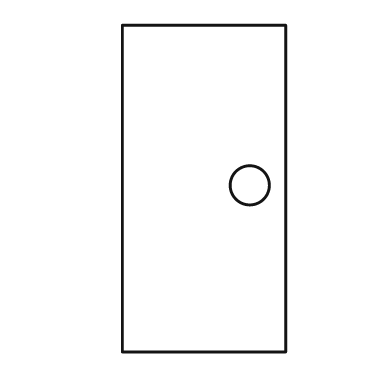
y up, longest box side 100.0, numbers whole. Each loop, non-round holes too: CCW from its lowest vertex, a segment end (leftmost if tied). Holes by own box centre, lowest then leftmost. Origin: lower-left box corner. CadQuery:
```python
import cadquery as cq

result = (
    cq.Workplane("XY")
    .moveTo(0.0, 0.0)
    .lineTo(50.0, 0.0)
    .lineTo(50.0, 100.0)
    .lineTo(0.0, 100.0)
    .close()
    .moveTo(39.0, 51.0)
    .circle(6.0)
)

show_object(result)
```